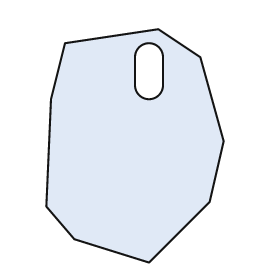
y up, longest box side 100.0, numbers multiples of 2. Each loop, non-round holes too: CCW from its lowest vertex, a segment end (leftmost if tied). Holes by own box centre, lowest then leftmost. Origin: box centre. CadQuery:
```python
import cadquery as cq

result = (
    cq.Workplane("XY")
    .moveTo(6.0, -50.0)
    .lineTo(32.0, -24.0)
    .lineTo(38.0, 2.0)
    .lineTo(28.0, 38.0)
    .lineTo(10.0, 50.0)
    .lineTo(-30.0, 44.0)
    .lineTo(-36.0, 20.0)
    .lineTo(-38.0, -26.0)
    .lineTo(-26.0, -40.0)
    .close()
    .moveTo(0.0, 26.0)
    .threePointArc((6.0, 20.0), (12.0, 26.0))
    .lineTo(12.0, 38.0)
    .threePointArc((6.0, 44.0), (0.0, 38.0))
    .close()
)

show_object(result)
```